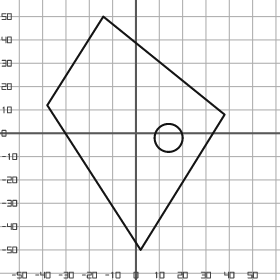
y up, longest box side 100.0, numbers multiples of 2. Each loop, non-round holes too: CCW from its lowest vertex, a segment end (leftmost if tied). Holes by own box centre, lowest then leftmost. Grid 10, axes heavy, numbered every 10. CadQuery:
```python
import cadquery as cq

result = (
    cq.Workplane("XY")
    .moveTo(2.0, -50.0)
    .lineTo(38.0, 8.0)
    .lineTo(-14.0, 50.0)
    .lineTo(-38.0, 12.0)
    .close()
    .moveTo(14.0, -2.0)
    .circle(6.0)
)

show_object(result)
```